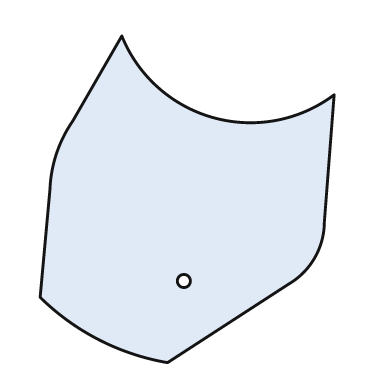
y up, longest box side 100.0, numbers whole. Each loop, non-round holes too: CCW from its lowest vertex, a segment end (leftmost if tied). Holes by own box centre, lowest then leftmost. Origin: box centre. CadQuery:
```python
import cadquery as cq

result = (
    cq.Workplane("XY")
    .moveTo(-6.0, -50.0)
    .lineTo(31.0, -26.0)
    .threePointArc((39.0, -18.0), (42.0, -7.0))
    .lineTo(45.0, 32.0)
    .threePointArc((8.0, 25.0), (-20.0, 50.0))
    .lineTo(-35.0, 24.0)
    .threePointArc((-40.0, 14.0), (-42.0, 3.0))
    .lineTo(-45.0, -30.0)
    .threePointArc((-27.0, -43.0), (-6.0, -50.0))
    .close()
    .moveTo(-1.0, -25.0)
    .circle(2.0)
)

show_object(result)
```